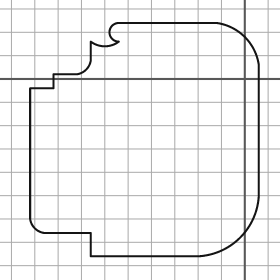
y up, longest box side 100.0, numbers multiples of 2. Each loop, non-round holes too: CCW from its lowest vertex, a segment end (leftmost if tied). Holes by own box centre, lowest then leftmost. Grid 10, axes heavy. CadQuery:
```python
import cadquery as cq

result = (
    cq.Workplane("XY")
    .moveTo(-66.0, -76.0)
    .lineTo(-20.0, -76.0)
    .threePointArc((-2.0, -68.0), (6.0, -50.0))
    .lineTo(6.0, 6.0)
    .threePointArc((0.0, 18.0), (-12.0, 24.0))
    .lineTo(-54.0, 24.0)
    .threePointArc((-58.0, 20.0), (-54.0, 16.0))
    .threePointArc((-60.0, 14.0), (-66.0, 16.0))
    .lineTo(-66.0, 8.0)
    .threePointArc((-68.0, 4.0), (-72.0, 2.0))
    .lineTo(-82.0, 2.0)
    .lineTo(-82.0, -4.0)
    .lineTo(-92.0, -4.0)
    .lineTo(-92.0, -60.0)
    .threePointArc((-90.0, -64.0), (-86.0, -66.0))
    .lineTo(-66.0, -66.0)
    .close()
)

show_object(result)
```